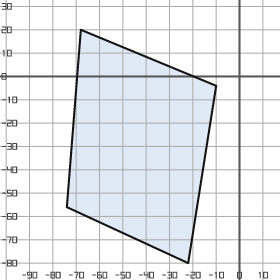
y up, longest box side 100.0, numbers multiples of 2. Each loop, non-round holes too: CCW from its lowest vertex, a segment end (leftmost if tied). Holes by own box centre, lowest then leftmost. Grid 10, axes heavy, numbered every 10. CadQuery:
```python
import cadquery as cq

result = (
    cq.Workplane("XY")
    .moveTo(-22.0, -80.0)
    .lineTo(-10.0, -4.0)
    .lineTo(-68.0, 20.0)
    .lineTo(-74.0, -56.0)
    .close()
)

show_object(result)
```